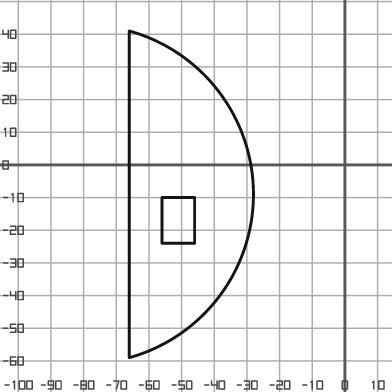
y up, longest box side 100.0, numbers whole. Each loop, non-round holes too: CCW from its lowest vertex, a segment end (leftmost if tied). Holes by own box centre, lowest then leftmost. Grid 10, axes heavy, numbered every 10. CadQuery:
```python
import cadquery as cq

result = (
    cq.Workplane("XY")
    .moveTo(-66.0, -59.0)
    .threePointArc((-28.0, -9.0), (-66.0, 41.0))
    .close()
    .moveTo(-56.0, -24.0)
    .lineTo(-46.0, -24.0)
    .lineTo(-46.0, -10.0)
    .lineTo(-56.0, -10.0)
    .close()
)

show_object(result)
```